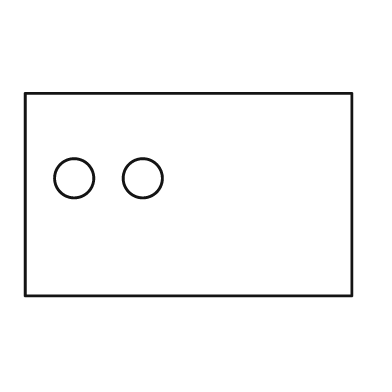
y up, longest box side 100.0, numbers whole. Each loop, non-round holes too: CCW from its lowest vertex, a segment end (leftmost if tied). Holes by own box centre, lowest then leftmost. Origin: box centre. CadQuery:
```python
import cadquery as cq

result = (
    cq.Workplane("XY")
    .moveTo(-50.0, -31.0)
    .lineTo(50.0, -31.0)
    .lineTo(50.0, 31.0)
    .lineTo(-50.0, 31.0)
    .close()
    .moveTo(-35.0, 5.0)
    .circle(6.0)
    .moveTo(-14.0, 5.0)
    .circle(6.0)
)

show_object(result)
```